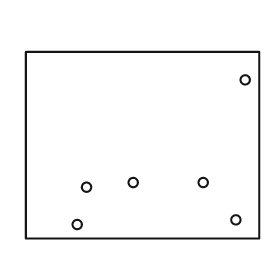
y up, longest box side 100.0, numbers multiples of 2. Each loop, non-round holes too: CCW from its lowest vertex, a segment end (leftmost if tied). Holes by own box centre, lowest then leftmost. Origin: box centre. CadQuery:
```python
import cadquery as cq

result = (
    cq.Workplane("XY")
    .moveTo(-50.0, -40.0)
    .lineTo(50.0, -40.0)
    .lineTo(50.0, 40.0)
    .lineTo(-50.0, 40.0)
    .close()
    .moveTo(-28.0, -34.0)
    .circle(2.0)
    .moveTo(40.0, -32.0)
    .circle(2.0)
    .moveTo(-24.0, -18.0)
    .circle(2.0)
    .moveTo(-4.0, -16.0)
    .circle(2.0)
    .moveTo(26.0, -16.0)
    .circle(2.0)
    .moveTo(44.0, 28.0)
    .circle(2.0)
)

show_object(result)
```